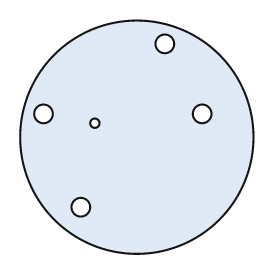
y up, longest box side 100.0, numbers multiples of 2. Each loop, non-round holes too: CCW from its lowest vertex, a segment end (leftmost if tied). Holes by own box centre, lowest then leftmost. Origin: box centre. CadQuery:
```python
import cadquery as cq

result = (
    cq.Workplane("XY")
    .moveTo(0.0, 0.0)
    .circle(50.0)
    .moveTo(-24.0, -30.0)
    .circle(4.0)
    .moveTo(-18.0, 6.0)
    .circle(2.0)
    .moveTo(-40.0, 10.0)
    .circle(4.0)
    .moveTo(28.0, 10.0)
    .circle(4.0)
    .moveTo(12.0, 40.0)
    .circle(4.0)
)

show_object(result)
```